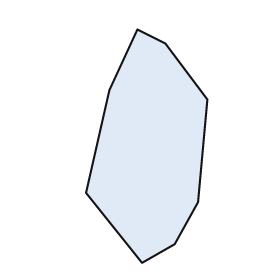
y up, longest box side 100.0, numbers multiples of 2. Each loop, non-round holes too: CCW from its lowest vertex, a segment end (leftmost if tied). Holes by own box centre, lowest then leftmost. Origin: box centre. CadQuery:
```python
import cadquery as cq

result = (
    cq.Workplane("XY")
    .moveTo(-2.0, -50.0)
    .lineTo(12.0, -42.0)
    .lineTo(22.0, -24.0)
    .lineTo(26.0, 20.0)
    .lineTo(8.0, 44.0)
    .lineTo(-4.0, 50.0)
    .lineTo(-16.0, 24.0)
    .lineTo(-26.0, -20.0)
    .close()
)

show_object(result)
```